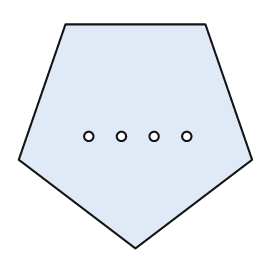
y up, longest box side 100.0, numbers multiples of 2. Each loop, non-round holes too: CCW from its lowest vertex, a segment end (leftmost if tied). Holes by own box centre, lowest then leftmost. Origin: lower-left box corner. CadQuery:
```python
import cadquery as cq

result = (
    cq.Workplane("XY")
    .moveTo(50.0, 0.0)
    .lineTo(100.0, 38.0)
    .lineTo(80.0, 96.0)
    .lineTo(20.0, 96.0)
    .lineTo(0.0, 38.0)
    .close()
    .moveTo(30.0, 48.0)
    .circle(2.0)
    .moveTo(44.0, 48.0)
    .circle(2.0)
    .moveTo(58.0, 48.0)
    .circle(2.0)
    .moveTo(72.0, 48.0)
    .circle(2.0)
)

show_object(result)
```